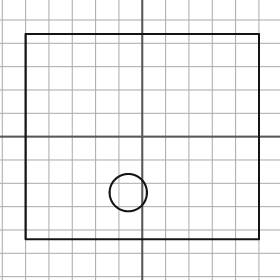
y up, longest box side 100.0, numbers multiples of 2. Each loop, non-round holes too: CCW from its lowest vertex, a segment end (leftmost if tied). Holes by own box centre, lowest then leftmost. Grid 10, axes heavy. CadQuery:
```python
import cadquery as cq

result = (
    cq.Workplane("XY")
    .moveTo(-50.0, -44.0)
    .lineTo(50.0, -44.0)
    .lineTo(50.0, 44.0)
    .lineTo(-50.0, 44.0)
    .close()
    .moveTo(-6.0, -24.0)
    .circle(8.0)
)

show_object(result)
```